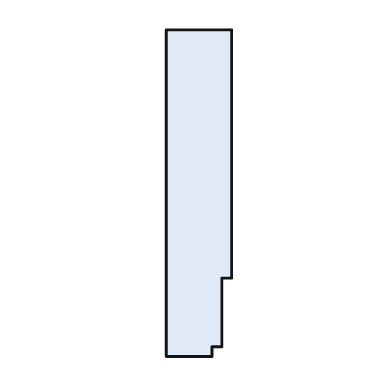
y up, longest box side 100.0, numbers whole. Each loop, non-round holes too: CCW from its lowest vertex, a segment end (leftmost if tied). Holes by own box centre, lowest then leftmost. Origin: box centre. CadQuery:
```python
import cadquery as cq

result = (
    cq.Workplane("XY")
    .moveTo(-10.0, -50.0)
    .lineTo(4.0, -50.0)
    .lineTo(4.0, -47.0)
    .lineTo(7.0, -47.0)
    .lineTo(7.0, -26.0)
    .lineTo(10.0, -26.0)
    .lineTo(10.0, 50.0)
    .lineTo(-10.0, 50.0)
    .close()
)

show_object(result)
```